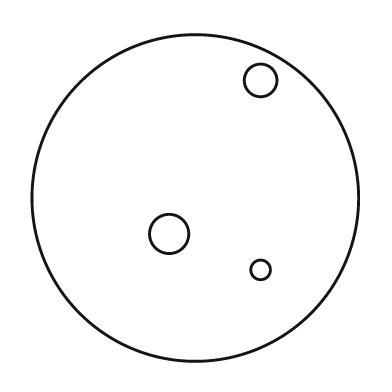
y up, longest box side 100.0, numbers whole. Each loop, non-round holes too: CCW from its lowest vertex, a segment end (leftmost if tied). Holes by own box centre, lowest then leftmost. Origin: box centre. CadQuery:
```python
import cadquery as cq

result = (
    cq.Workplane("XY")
    .moveTo(0.0, 0.0)
    .circle(50.0)
    .moveTo(20.0, -22.0)
    .circle(3.0)
    .moveTo(-8.0, -11.0)
    .circle(6.0)
    .moveTo(20.0, 36.0)
    .circle(5.0)
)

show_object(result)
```